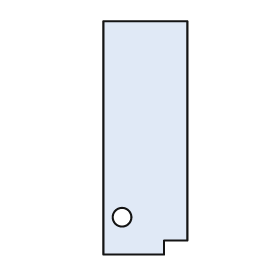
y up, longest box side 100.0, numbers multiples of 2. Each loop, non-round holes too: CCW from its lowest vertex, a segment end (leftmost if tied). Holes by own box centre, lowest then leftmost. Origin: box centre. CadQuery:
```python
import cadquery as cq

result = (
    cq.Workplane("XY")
    .moveTo(-18.0, -50.0)
    .lineTo(8.0, -50.0)
    .lineTo(8.0, -44.0)
    .lineTo(18.0, -44.0)
    .lineTo(18.0, 50.0)
    .lineTo(-18.0, 50.0)
    .close()
    .moveTo(-10.0, -34.0)
    .circle(4.0)
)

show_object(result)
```